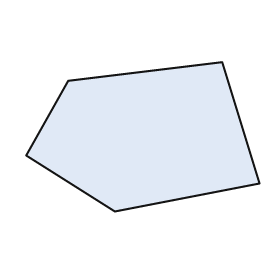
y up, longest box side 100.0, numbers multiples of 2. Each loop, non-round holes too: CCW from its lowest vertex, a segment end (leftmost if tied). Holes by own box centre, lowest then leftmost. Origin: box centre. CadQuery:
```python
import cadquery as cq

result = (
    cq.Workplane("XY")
    .moveTo(-12.0, -32.0)
    .lineTo(50.0, -20.0)
    .lineTo(34.0, 32.0)
    .lineTo(-32.0, 24.0)
    .lineTo(-50.0, -8.0)
    .close()
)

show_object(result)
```